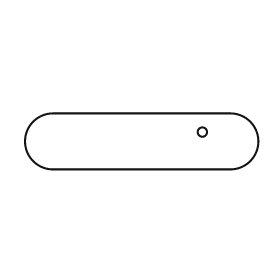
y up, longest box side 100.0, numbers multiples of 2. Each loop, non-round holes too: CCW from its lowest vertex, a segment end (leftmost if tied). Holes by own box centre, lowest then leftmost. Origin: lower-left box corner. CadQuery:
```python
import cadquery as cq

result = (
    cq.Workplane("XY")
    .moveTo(12.0, 0.0)
    .lineTo(88.0, 0.0)
    .threePointArc((100.0, 12.0), (88.0, 24.0))
    .lineTo(12.0, 24.0)
    .threePointArc((0.0, 12.0), (12.0, 0.0))
    .close()
    .moveTo(76.0, 16.0)
    .circle(2.0)
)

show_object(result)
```